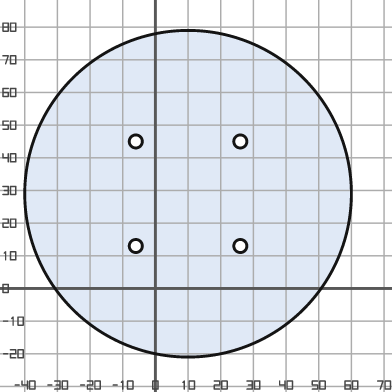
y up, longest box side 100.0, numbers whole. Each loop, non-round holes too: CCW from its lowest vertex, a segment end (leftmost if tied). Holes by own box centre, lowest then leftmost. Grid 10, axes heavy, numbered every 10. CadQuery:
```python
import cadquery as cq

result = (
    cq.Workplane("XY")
    .moveTo(10.0, 29.0)
    .circle(50.0)
    .moveTo(-6.0, 13.0)
    .circle(2.0)
    .moveTo(26.0, 13.0)
    .circle(2.0)
    .moveTo(-6.0, 45.0)
    .circle(2.0)
    .moveTo(26.0, 45.0)
    .circle(2.0)
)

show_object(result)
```